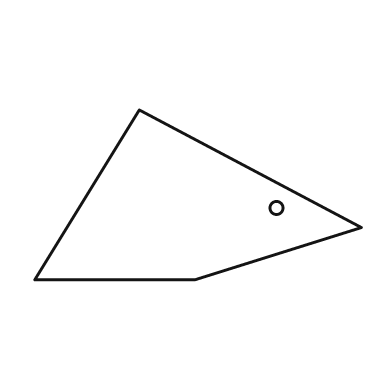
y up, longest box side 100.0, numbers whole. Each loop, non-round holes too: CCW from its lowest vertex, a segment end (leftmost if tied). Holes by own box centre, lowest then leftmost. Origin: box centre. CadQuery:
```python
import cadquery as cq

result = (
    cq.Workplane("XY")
    .moveTo(-50.0, -26.0)
    .lineTo(-1.0, -26.0)
    .lineTo(50.0, -10.0)
    .lineTo(-18.0, 26.0)
    .close()
    .moveTo(24.0, -4.0)
    .circle(2.0)
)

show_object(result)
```